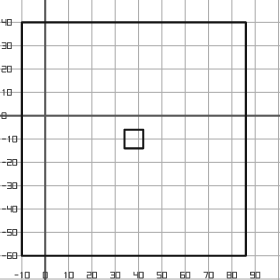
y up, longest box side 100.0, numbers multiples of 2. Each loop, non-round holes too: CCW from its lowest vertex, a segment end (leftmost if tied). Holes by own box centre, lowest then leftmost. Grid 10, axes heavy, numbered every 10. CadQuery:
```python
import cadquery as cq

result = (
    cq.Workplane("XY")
    .moveTo(-10.0, -60.0)
    .lineTo(86.0, -60.0)
    .lineTo(86.0, 40.0)
    .lineTo(-10.0, 40.0)
    .close()
    .moveTo(34.0, -14.0)
    .lineTo(42.0, -14.0)
    .lineTo(42.0, -6.0)
    .lineTo(34.0, -6.0)
    .close()
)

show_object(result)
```